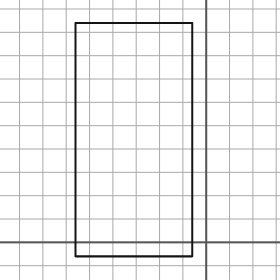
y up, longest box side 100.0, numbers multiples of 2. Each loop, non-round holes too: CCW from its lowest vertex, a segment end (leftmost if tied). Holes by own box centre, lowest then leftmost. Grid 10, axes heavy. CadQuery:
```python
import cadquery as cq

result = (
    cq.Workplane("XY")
    .moveTo(-56.0, -6.0)
    .lineTo(-6.0, -6.0)
    .lineTo(-6.0, 94.0)
    .lineTo(-56.0, 94.0)
    .close()
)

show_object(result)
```